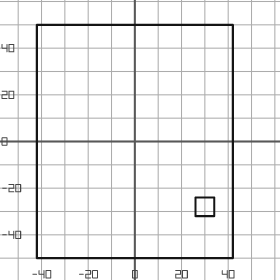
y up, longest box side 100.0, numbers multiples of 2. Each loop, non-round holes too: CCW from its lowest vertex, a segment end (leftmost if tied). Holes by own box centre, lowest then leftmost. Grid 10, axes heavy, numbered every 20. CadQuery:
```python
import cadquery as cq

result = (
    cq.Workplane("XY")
    .moveTo(-42.0, -50.0)
    .lineTo(42.0, -50.0)
    .lineTo(42.0, 50.0)
    .lineTo(-42.0, 50.0)
    .close()
    .moveTo(26.0, -32.0)
    .lineTo(34.0, -32.0)
    .lineTo(34.0, -24.0)
    .lineTo(26.0, -24.0)
    .close()
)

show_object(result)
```